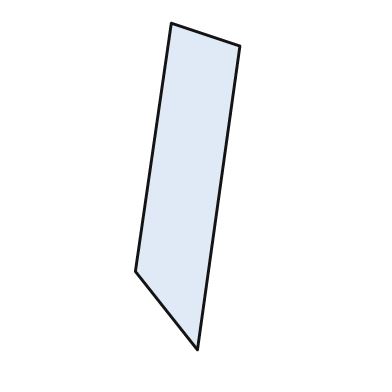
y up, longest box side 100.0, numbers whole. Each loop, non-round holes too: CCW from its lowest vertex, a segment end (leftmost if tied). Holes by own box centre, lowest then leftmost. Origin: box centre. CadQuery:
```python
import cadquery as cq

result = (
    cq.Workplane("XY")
    .moveTo(3.0, -50.0)
    .lineTo(16.0, 43.0)
    .lineTo(-5.0, 50.0)
    .lineTo(-16.0, -26.0)
    .close()
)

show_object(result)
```